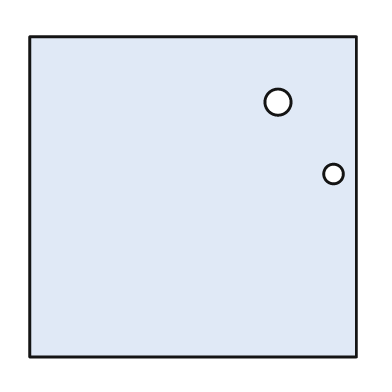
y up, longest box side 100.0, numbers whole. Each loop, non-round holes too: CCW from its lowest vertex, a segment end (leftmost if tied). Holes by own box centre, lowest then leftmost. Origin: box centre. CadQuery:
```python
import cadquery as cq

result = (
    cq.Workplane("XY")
    .moveTo(-50.0, -49.0)
    .lineTo(50.0, -49.0)
    .lineTo(50.0, 49.0)
    .lineTo(-50.0, 49.0)
    .close()
    .moveTo(43.0, 7.0)
    .circle(3.0)
    .moveTo(26.0, 29.0)
    .circle(4.0)
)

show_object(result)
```